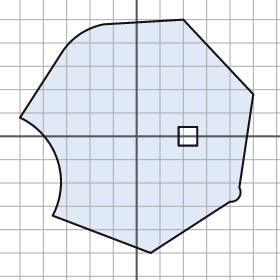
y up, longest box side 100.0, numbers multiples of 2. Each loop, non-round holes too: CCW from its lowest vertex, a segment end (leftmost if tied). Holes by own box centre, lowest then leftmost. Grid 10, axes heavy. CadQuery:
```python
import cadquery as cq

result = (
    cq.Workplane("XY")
    .moveTo(6.0, -50.0)
    .lineTo(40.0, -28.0)
    .threePointArc((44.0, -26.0), (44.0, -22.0))
    .lineTo(50.0, 18.0)
    .lineTo(20.0, 50.0)
    .lineTo(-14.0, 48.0)
    .threePointArc((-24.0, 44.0), (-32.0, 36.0))
    .lineTo(-50.0, 8.0)
    .threePointArc((-34.0, -10.0), (-36.0, -34.0))
    .close()
    .moveTo(18.0, -4.0)
    .lineTo(26.0, -4.0)
    .lineTo(26.0, 4.0)
    .lineTo(18.0, 4.0)
    .close()
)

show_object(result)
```